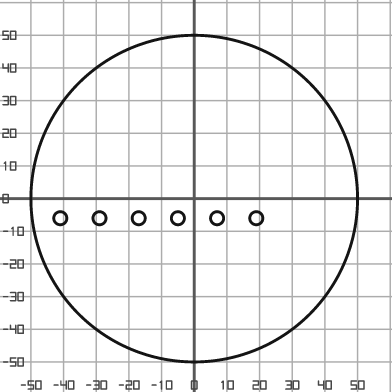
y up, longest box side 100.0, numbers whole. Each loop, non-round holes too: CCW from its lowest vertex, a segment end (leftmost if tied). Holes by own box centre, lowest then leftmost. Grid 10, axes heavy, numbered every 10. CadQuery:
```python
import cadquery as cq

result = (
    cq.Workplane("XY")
    .moveTo(0.0, 0.0)
    .circle(50.0)
    .moveTo(-41.0, -6.0)
    .circle(2.0)
    .moveTo(-29.0, -6.0)
    .circle(2.0)
    .moveTo(-17.0, -6.0)
    .circle(2.0)
    .moveTo(-5.0, -6.0)
    .circle(2.0)
    .moveTo(7.0, -6.0)
    .circle(2.0)
    .moveTo(19.0, -6.0)
    .circle(2.0)
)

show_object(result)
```